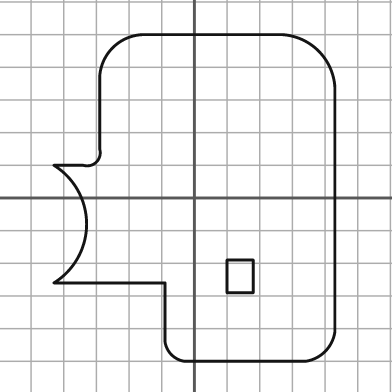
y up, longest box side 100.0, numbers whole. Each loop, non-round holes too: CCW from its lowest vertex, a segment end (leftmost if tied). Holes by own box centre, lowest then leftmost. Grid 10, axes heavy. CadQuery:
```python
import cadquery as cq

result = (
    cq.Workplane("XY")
    .moveTo(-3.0, -50.0)
    .lineTo(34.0, -50.0)
    .threePointArc((40.0, -47.0), (43.0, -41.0))
    .lineTo(43.0, 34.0)
    .threePointArc((38.0, 45.0), (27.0, 50.0))
    .lineTo(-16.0, 50.0)
    .threePointArc((-25.0, 46.0), (-29.0, 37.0))
    .lineTo(-29.0, 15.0)
    .threePointArc((-30.0, 11.0), (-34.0, 10.0))
    .lineTo(-43.0, 10.0)
    .threePointArc((-33.0, -8.0), (-43.0, -26.0))
    .lineTo(-9.0, -26.0)
    .lineTo(-9.0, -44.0)
    .threePointArc((-7.0, -48.0), (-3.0, -50.0))
    .close()
    .moveTo(10.0, -29.0)
    .lineTo(18.0, -29.0)
    .lineTo(18.0, -19.0)
    .lineTo(10.0, -19.0)
    .close()
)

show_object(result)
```